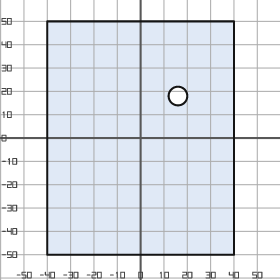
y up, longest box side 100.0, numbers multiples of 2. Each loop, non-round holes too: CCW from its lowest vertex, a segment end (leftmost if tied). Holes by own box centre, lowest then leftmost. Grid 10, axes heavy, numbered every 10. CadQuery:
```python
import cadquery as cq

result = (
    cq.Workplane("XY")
    .moveTo(-40.0, -50.0)
    .lineTo(40.0, -50.0)
    .lineTo(40.0, 50.0)
    .lineTo(-40.0, 50.0)
    .close()
    .moveTo(16.0, 18.0)
    .circle(4.0)
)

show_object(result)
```